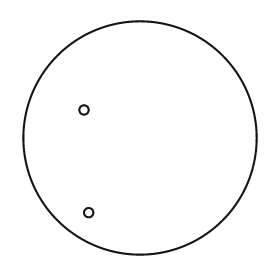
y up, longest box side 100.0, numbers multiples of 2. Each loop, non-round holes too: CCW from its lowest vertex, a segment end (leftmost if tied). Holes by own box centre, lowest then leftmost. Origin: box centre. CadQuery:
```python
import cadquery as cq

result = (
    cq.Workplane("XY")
    .moveTo(0.0, 0.0)
    .circle(50.0)
    .moveTo(-22.0, -32.0)
    .circle(2.0)
    .moveTo(-24.0, 12.0)
    .circle(2.0)
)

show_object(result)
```